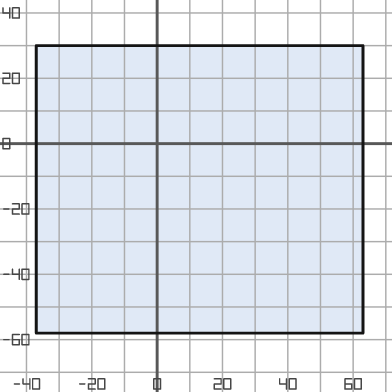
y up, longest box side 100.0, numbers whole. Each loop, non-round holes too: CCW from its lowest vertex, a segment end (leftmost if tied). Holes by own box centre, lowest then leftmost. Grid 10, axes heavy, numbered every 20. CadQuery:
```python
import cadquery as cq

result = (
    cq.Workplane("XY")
    .moveTo(-37.0, -58.0)
    .lineTo(63.0, -58.0)
    .lineTo(63.0, 30.0)
    .lineTo(-37.0, 30.0)
    .close()
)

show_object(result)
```